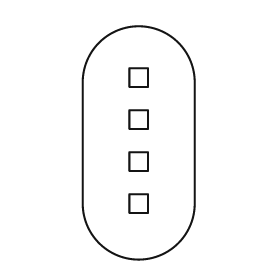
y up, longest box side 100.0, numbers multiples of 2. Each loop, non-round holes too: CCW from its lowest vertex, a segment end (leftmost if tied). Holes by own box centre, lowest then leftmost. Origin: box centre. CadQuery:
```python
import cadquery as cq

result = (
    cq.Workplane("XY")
    .moveTo(-24.0, -26.0)
    .threePointArc((0.0, -50.0), (24.0, -26.0))
    .lineTo(24.0, 26.0)
    .threePointArc((0.0, 50.0), (-24.0, 26.0))
    .close()
    .moveTo(-4.0, -30.0)
    .lineTo(4.0, -30.0)
    .lineTo(4.0, -22.0)
    .lineTo(-4.0, -22.0)
    .close()
    .moveTo(-4.0, -12.0)
    .lineTo(4.0, -12.0)
    .lineTo(4.0, -4.0)
    .lineTo(-4.0, -4.0)
    .close()
    .moveTo(-4.0, 6.0)
    .lineTo(4.0, 6.0)
    .lineTo(4.0, 14.0)
    .lineTo(-4.0, 14.0)
    .close()
    .moveTo(-4.0, 24.0)
    .lineTo(4.0, 24.0)
    .lineTo(4.0, 32.0)
    .lineTo(-4.0, 32.0)
    .close()
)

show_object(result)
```